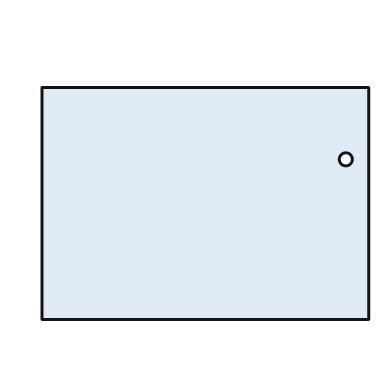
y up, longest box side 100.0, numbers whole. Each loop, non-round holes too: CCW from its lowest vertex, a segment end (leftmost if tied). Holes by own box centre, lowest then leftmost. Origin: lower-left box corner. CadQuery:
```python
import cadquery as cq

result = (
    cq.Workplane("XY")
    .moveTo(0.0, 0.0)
    .lineTo(100.0, 0.0)
    .lineTo(100.0, 71.0)
    .lineTo(0.0, 71.0)
    .close()
    .moveTo(93.0, 49.0)
    .circle(2.0)
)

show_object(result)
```